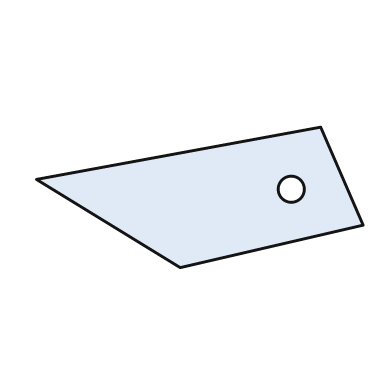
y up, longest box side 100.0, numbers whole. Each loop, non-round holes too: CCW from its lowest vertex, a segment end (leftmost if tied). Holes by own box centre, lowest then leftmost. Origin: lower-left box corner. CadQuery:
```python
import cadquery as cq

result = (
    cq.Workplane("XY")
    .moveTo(44.0, 0.0)
    .lineTo(100.0, 13.0)
    .lineTo(87.0, 43.0)
    .lineTo(0.0, 27.0)
    .close()
    .moveTo(78.0, 24.0)
    .circle(4.0)
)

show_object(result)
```